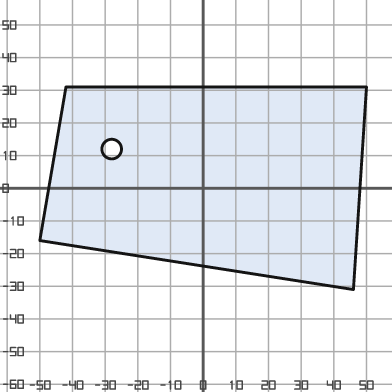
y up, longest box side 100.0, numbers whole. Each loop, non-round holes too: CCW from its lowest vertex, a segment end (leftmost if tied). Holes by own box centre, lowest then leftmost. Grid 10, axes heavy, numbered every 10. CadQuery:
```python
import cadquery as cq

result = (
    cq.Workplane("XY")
    .moveTo(46.0, -31.0)
    .lineTo(50.0, 31.0)
    .lineTo(-42.0, 31.0)
    .lineTo(-50.0, -16.0)
    .close()
    .moveTo(-28.0, 12.0)
    .circle(3.0)
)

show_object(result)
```